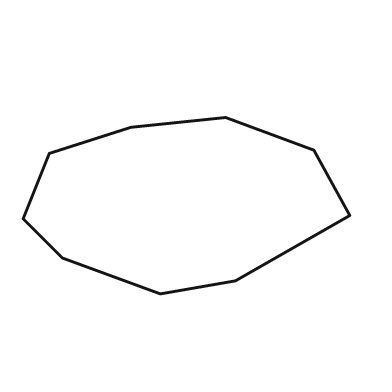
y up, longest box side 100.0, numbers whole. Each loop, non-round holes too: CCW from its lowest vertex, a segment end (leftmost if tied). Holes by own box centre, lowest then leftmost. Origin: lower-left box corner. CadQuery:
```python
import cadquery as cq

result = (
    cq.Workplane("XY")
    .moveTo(42.0, 0.0)
    .lineTo(65.0, 4.0)
    .lineTo(100.0, 24.0)
    .lineTo(89.0, 44.0)
    .lineTo(62.0, 54.0)
    .lineTo(33.0, 51.0)
    .lineTo(8.0, 43.0)
    .lineTo(0.0, 23.0)
    .lineTo(12.0, 11.0)
    .close()
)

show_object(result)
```